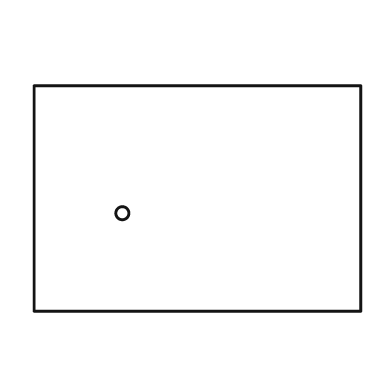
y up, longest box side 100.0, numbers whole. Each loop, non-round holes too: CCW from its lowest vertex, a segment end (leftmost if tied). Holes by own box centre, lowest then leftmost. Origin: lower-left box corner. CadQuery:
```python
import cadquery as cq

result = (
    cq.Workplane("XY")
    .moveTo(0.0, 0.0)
    .lineTo(100.0, 0.0)
    .lineTo(100.0, 69.0)
    .lineTo(0.0, 69.0)
    .close()
    .moveTo(27.0, 30.0)
    .circle(2.0)
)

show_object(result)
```